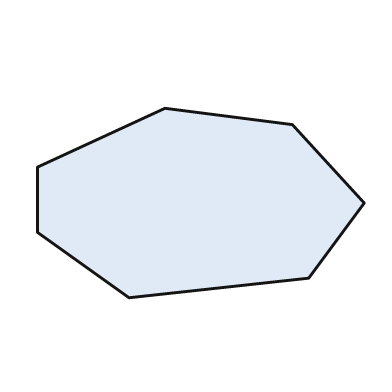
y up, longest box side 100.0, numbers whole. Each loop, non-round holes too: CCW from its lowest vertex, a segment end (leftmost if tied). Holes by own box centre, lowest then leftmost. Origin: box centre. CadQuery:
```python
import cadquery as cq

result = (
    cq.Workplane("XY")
    .moveTo(-22.0, -29.0)
    .lineTo(33.0, -23.0)
    .lineTo(50.0, 0.0)
    .lineTo(28.0, 24.0)
    .lineTo(-11.0, 29.0)
    .lineTo(-50.0, 11.0)
    .lineTo(-50.0, -9.0)
    .close()
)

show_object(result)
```